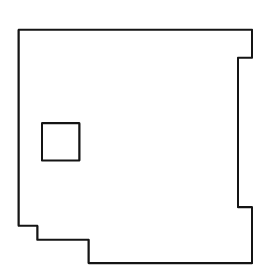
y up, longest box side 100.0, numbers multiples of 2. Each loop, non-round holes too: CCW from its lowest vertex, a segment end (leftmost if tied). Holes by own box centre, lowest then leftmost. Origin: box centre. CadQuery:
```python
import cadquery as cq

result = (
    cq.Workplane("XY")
    .moveTo(-20.0, -50.0)
    .lineTo(50.0, -50.0)
    .lineTo(50.0, -26.0)
    .lineTo(44.0, -26.0)
    .lineTo(44.0, 38.0)
    .lineTo(50.0, 38.0)
    .lineTo(50.0, 50.0)
    .lineTo(-50.0, 50.0)
    .lineTo(-50.0, -34.0)
    .lineTo(-42.0, -34.0)
    .lineTo(-42.0, -40.0)
    .lineTo(-20.0, -40.0)
    .close()
    .moveTo(-40.0, -6.0)
    .lineTo(-24.0, -6.0)
    .lineTo(-24.0, 10.0)
    .lineTo(-40.0, 10.0)
    .close()
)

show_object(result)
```